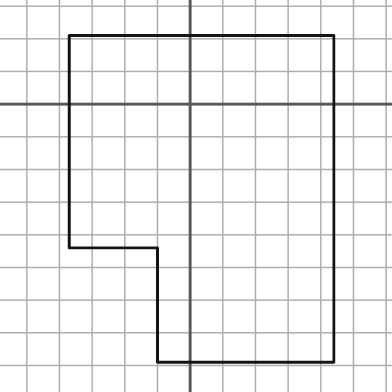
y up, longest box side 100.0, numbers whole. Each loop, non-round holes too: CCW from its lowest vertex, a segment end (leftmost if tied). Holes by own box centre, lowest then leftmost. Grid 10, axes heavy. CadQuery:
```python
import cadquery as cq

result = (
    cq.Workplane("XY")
    .moveTo(-10.0, -79.0)
    .lineTo(44.0, -79.0)
    .lineTo(44.0, 21.0)
    .lineTo(-37.0, 21.0)
    .lineTo(-37.0, -44.0)
    .lineTo(-10.0, -44.0)
    .close()
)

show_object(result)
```